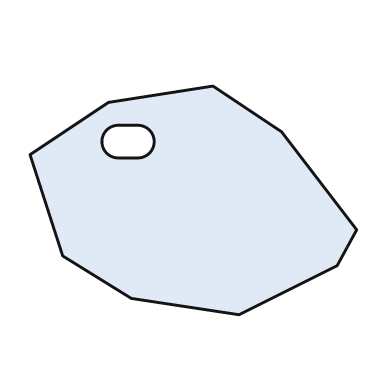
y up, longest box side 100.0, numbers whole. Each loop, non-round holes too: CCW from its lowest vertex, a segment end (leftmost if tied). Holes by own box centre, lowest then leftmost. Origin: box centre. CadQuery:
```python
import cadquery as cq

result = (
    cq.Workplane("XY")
    .moveTo(14.0, -35.0)
    .lineTo(44.0, -20.0)
    .lineTo(50.0, -9.0)
    .lineTo(27.0, 21.0)
    .lineTo(6.0, 35.0)
    .lineTo(-26.0, 30.0)
    .lineTo(-50.0, 14.0)
    .lineTo(-40.0, -17.0)
    .lineTo(-19.0, -30.0)
    .close()
    .moveTo(-23.0, 13.0)
    .lineTo(-17.0, 13.0)
    .threePointArc((-12.0, 18.0), (-17.0, 23.0))
    .lineTo(-23.0, 23.0)
    .threePointArc((-28.0, 18.0), (-23.0, 13.0))
    .close()
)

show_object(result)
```